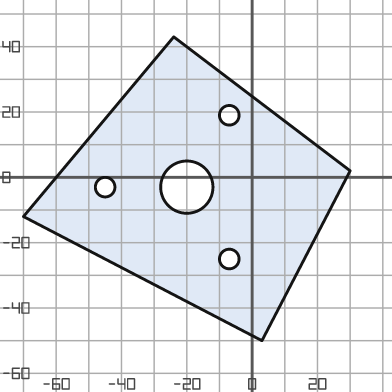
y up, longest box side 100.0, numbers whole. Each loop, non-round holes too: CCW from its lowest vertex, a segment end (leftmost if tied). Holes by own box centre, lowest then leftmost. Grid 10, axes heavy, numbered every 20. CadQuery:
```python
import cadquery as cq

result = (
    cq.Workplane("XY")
    .moveTo(3.0, -50.0)
    .lineTo(30.0, 2.0)
    .lineTo(-24.0, 43.0)
    .lineTo(-70.0, -12.0)
    .close()
    .moveTo(-7.0, -25.0)
    .circle(3.0)
    .moveTo(-45.0, -3.0)
    .circle(3.0)
    .moveTo(-20.0, -3.0)
    .circle(8.0)
    .moveTo(-7.0, 19.0)
    .circle(3.0)
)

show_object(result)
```